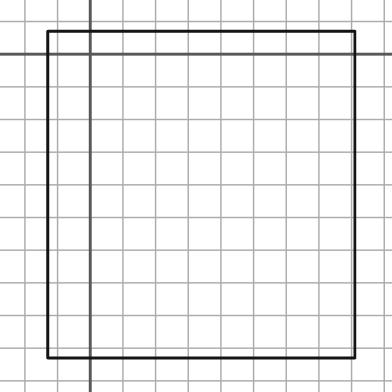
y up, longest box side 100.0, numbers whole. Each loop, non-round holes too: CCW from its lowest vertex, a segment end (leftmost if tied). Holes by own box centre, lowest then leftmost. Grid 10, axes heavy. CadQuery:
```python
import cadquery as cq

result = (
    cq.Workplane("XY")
    .moveTo(-13.0, -93.0)
    .lineTo(81.0, -93.0)
    .lineTo(81.0, 7.0)
    .lineTo(-13.0, 7.0)
    .close()
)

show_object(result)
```